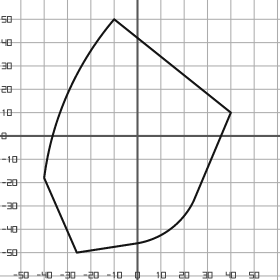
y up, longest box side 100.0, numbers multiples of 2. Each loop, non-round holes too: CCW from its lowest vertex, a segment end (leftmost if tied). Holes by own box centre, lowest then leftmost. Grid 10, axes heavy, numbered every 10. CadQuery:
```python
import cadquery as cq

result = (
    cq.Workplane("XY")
    .moveTo(-26.0, -50.0)
    .lineTo(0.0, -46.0)
    .threePointArc((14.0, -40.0), (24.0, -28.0))
    .lineTo(40.0, 10.0)
    .lineTo(-10.0, 50.0)
    .threePointArc((-30.0, 18.0), (-40.0, -18.0))
    .close()
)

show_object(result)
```